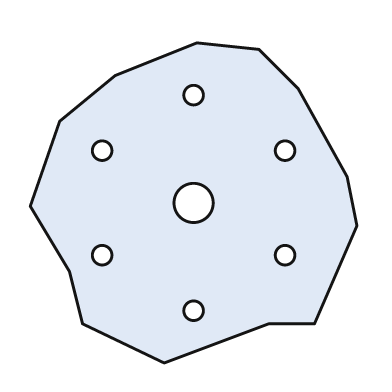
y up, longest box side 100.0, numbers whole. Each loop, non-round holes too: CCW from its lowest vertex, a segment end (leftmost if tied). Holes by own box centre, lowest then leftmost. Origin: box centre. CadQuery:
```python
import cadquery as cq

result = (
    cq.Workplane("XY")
    .moveTo(-9.0, -49.0)
    .lineTo(23.0, -37.0)
    .lineTo(37.0, -37.0)
    .lineTo(50.0, -7.0)
    .lineTo(47.0, 8.0)
    .lineTo(32.0, 35.0)
    .lineTo(20.0, 47.0)
    .lineTo(1.0, 49.0)
    .lineTo(-24.0, 39.0)
    .lineTo(-41.0, 25.0)
    .lineTo(-50.0, -1.0)
    .lineTo(-38.0, -21.0)
    .lineTo(-34.0, -37.0)
    .close()
    .moveTo(0.0, -33.0)
    .circle(3.0)
    .moveTo(-28.0, -16.0)
    .circle(3.0)
    .moveTo(28.0, -16.0)
    .circle(3.0)
    .moveTo(0.0, 0.0)
    .circle(6.0)
    .moveTo(-28.0, 16.0)
    .circle(3.0)
    .moveTo(28.0, 16.0)
    .circle(3.0)
    .moveTo(0.0, 33.0)
    .circle(3.0)
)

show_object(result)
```